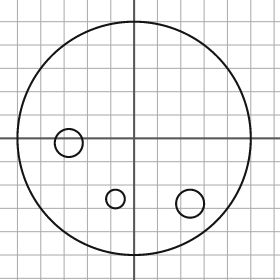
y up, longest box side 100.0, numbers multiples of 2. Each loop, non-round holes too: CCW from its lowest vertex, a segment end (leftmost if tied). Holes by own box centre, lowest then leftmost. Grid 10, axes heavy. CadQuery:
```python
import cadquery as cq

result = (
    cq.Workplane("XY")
    .moveTo(0.0, 0.0)
    .circle(50.0)
    .moveTo(24.0, -28.0)
    .circle(6.0)
    .moveTo(-8.0, -26.0)
    .circle(4.0)
    .moveTo(-28.0, -2.0)
    .circle(6.0)
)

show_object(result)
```